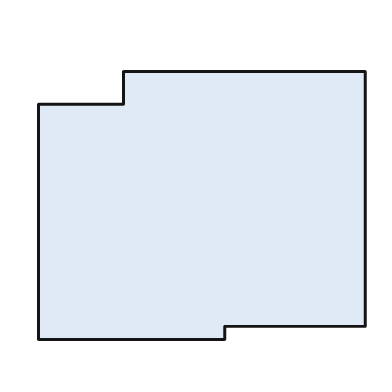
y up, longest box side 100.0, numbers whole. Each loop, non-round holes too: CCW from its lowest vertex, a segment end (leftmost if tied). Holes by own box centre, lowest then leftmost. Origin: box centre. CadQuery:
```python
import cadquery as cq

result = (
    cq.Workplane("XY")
    .moveTo(-50.0, -41.0)
    .lineTo(7.0, -41.0)
    .lineTo(7.0, -37.0)
    .lineTo(50.0, -37.0)
    .lineTo(50.0, 41.0)
    .lineTo(-24.0, 41.0)
    .lineTo(-24.0, 31.0)
    .lineTo(-50.0, 31.0)
    .close()
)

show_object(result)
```